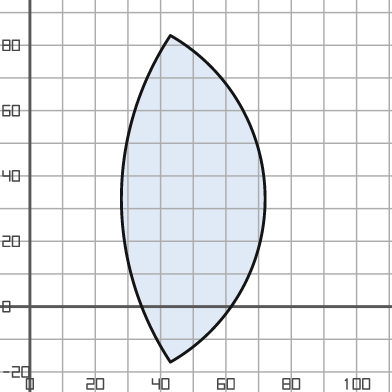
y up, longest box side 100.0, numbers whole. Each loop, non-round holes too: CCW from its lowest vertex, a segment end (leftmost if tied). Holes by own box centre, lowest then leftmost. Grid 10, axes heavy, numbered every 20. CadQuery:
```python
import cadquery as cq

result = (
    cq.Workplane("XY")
    .moveTo(43.0, -17.0)
    .threePointArc((72.0, 33.0), (43.0, 83.0))
    .threePointArc((28.0, 33.0), (43.0, -17.0))
    .close()
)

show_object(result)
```